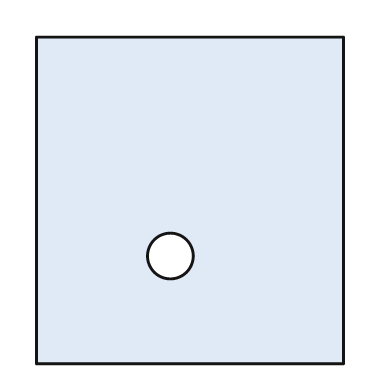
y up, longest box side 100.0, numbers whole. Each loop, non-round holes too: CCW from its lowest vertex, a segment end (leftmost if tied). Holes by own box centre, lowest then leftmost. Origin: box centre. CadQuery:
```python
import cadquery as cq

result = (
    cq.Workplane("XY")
    .moveTo(-47.0, -50.0)
    .lineTo(47.0, -50.0)
    .lineTo(47.0, 50.0)
    .lineTo(-47.0, 50.0)
    .close()
    .moveTo(-6.0, -17.0)
    .circle(7.0)
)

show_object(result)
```